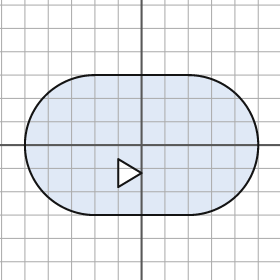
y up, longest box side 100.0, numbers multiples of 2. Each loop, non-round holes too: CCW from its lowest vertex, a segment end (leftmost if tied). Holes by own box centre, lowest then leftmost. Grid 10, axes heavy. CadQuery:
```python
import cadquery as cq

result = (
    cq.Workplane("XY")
    .moveTo(-20.0, -30.0)
    .lineTo(20.0, -30.0)
    .threePointArc((50.0, 0.0), (20.0, 30.0))
    .lineTo(-20.0, 30.0)
    .threePointArc((-50.0, 0.0), (-20.0, -30.0))
    .close()
    .moveTo(-10.0, -18.0)
    .lineTo(0.0, -12.0)
    .lineTo(-10.0, -6.0)
    .close()
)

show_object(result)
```